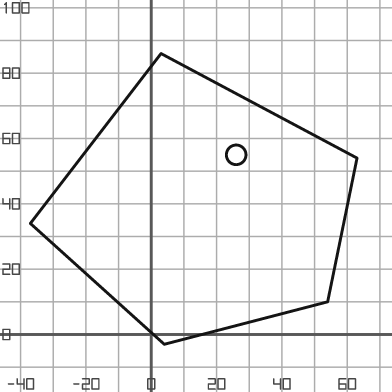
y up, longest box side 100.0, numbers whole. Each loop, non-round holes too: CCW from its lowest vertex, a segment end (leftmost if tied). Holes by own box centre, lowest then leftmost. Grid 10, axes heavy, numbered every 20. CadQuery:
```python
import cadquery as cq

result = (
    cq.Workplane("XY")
    .moveTo(4.0, -3.0)
    .lineTo(54.0, 10.0)
    .lineTo(63.0, 54.0)
    .lineTo(3.0, 86.0)
    .lineTo(-37.0, 34.0)
    .close()
    .moveTo(26.0, 55.0)
    .circle(3.0)
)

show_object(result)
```